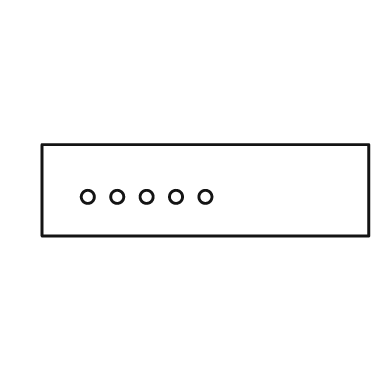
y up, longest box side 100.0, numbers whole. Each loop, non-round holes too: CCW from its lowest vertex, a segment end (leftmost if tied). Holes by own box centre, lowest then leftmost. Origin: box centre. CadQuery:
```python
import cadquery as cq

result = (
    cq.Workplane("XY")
    .moveTo(-50.0, -14.0)
    .lineTo(50.0, -14.0)
    .lineTo(50.0, 14.0)
    .lineTo(-50.0, 14.0)
    .close()
    .moveTo(-36.0, -2.0)
    .circle(2.0)
    .moveTo(-27.0, -2.0)
    .circle(2.0)
    .moveTo(-18.0, -2.0)
    .circle(2.0)
    .moveTo(-9.0, -2.0)
    .circle(2.0)
    .moveTo(0.0, -2.0)
    .circle(2.0)
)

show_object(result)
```